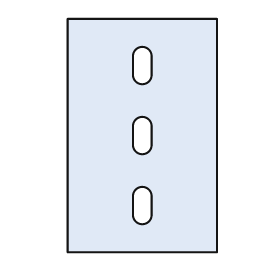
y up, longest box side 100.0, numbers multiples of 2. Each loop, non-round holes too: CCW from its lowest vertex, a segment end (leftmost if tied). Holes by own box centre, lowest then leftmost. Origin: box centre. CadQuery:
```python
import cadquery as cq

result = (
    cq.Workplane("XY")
    .moveTo(-32.0, -50.0)
    .lineTo(32.0, -50.0)
    .lineTo(32.0, 50.0)
    .lineTo(-32.0, 50.0)
    .close()
    .moveTo(-4.0, -34.0)
    .threePointArc((0.0, -38.0), (4.0, -34.0))
    .lineTo(4.0, -26.0)
    .threePointArc((0.0, -22.0), (-4.0, -26.0))
    .close()
    .moveTo(-4.0, -4.0)
    .threePointArc((0.0, -8.0), (4.0, -4.0))
    .lineTo(4.0, 4.0)
    .threePointArc((0.0, 8.0), (-4.0, 4.0))
    .close()
    .moveTo(-4.0, 26.0)
    .threePointArc((0.0, 22.0), (4.0, 26.0))
    .lineTo(4.0, 34.0)
    .threePointArc((0.0, 38.0), (-4.0, 34.0))
    .close()
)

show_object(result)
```